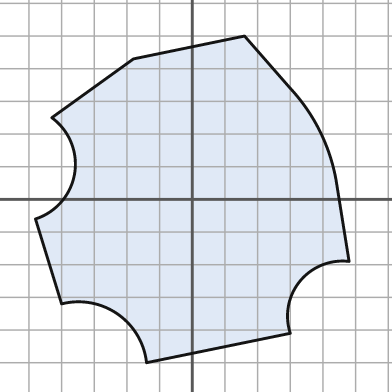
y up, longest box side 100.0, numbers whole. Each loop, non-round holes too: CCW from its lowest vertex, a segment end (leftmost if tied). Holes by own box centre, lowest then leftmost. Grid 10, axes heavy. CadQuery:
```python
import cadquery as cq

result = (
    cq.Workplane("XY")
    .moveTo(-14.0, -50.0)
    .lineTo(30.0, -41.0)
    .threePointArc((33.0, -25.0), (48.0, -19.0))
    .lineTo(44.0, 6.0)
    .threePointArc((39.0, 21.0), (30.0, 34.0))
    .lineTo(16.0, 50.0)
    .lineTo(-18.0, 43.0)
    .lineTo(-43.0, 25.0)
    .threePointArc((-36.0, 8.0), (-48.0, -6.0))
    .lineTo(-40.0, -32.0)
    .threePointArc((-23.0, -35.0), (-14.0, -50.0))
    .close()
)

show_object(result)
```